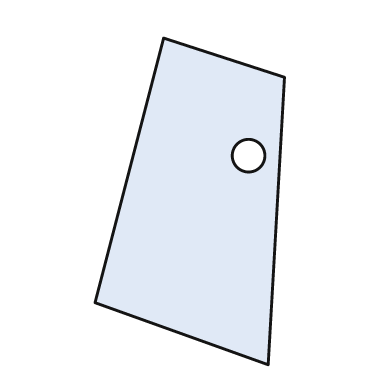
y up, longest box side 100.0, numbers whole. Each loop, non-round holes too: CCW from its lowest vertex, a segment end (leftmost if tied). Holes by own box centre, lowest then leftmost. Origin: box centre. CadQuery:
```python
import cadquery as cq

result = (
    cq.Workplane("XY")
    .moveTo(24.0, -50.0)
    .lineTo(29.0, 38.0)
    .lineTo(-8.0, 50.0)
    .lineTo(-29.0, -31.0)
    .close()
    .moveTo(18.0, 14.0)
    .circle(5.0)
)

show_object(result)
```